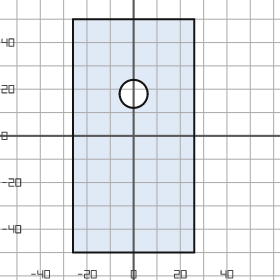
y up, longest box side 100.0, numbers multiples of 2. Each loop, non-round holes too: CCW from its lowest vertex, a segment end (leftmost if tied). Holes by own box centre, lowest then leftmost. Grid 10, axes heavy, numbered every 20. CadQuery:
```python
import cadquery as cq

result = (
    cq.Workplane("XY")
    .moveTo(-26.0, -50.0)
    .lineTo(26.0, -50.0)
    .lineTo(26.0, 50.0)
    .lineTo(-26.0, 50.0)
    .close()
    .moveTo(0.0, 18.0)
    .circle(6.0)
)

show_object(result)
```